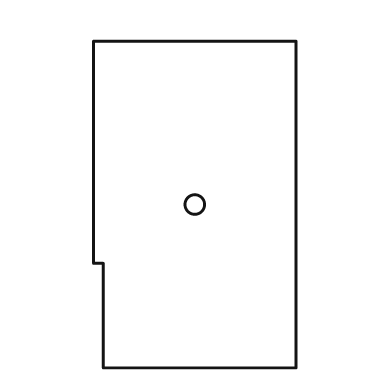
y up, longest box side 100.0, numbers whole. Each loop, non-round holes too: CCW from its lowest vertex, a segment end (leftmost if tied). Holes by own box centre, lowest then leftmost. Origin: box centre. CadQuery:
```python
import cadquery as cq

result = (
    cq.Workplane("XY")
    .moveTo(-28.0, -50.0)
    .lineTo(31.0, -50.0)
    .lineTo(31.0, 50.0)
    .lineTo(-31.0, 50.0)
    .lineTo(-31.0, -18.0)
    .lineTo(-28.0, -18.0)
    .close()
    .moveTo(0.0, 0.0)
    .circle(3.0)
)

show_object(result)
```